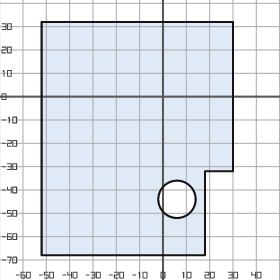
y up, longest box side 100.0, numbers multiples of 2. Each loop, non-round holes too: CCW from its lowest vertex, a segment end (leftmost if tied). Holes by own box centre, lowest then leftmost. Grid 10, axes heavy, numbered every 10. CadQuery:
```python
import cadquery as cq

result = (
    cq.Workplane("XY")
    .moveTo(-52.0, -68.0)
    .lineTo(18.0, -68.0)
    .lineTo(18.0, -32.0)
    .lineTo(30.0, -32.0)
    .lineTo(30.0, 32.0)
    .lineTo(-52.0, 32.0)
    .close()
    .moveTo(6.0, -44.0)
    .circle(8.0)
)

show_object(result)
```